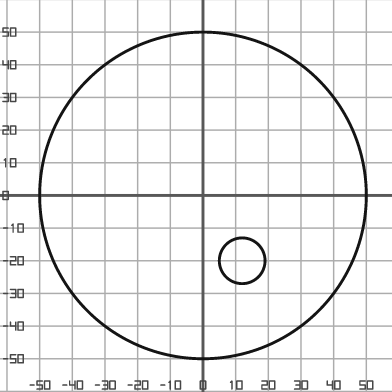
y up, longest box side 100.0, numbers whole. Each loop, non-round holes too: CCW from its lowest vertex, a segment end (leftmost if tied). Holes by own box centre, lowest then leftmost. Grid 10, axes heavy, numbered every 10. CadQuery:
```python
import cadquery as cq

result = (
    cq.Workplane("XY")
    .moveTo(0.0, 0.0)
    .circle(50.0)
    .moveTo(12.0, -20.0)
    .circle(7.0)
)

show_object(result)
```